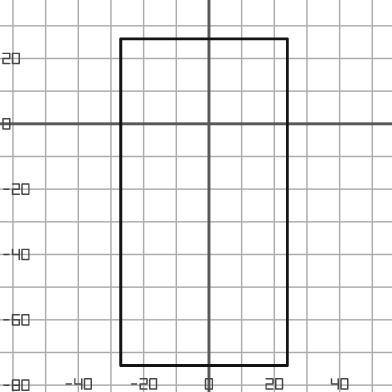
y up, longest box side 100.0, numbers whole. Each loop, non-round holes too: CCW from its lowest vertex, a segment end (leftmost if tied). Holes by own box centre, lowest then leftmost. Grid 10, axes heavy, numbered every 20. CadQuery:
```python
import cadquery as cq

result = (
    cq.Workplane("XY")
    .moveTo(-27.0, -74.0)
    .lineTo(24.0, -74.0)
    .lineTo(24.0, 26.0)
    .lineTo(-27.0, 26.0)
    .close()
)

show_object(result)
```